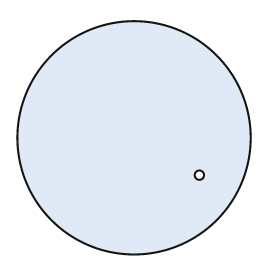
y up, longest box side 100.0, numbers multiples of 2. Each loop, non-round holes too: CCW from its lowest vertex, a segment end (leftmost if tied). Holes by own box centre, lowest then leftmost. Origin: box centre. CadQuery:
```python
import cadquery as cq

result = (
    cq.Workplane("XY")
    .moveTo(0.0, 0.0)
    .circle(50.0)
    .moveTo(28.0, -16.0)
    .circle(2.0)
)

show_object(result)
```